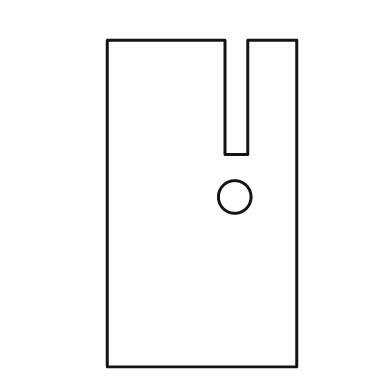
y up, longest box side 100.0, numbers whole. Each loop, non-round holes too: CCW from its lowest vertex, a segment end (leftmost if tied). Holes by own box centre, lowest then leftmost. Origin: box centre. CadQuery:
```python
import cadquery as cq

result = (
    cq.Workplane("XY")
    .moveTo(-29.0, -50.0)
    .lineTo(29.0, -50.0)
    .lineTo(29.0, 50.0)
    .lineTo(14.0, 50.0)
    .lineTo(14.0, 15.0)
    .lineTo(7.0, 15.0)
    .lineTo(7.0, 50.0)
    .lineTo(-29.0, 50.0)
    .close()
    .moveTo(10.0, 2.0)
    .circle(5.0)
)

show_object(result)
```